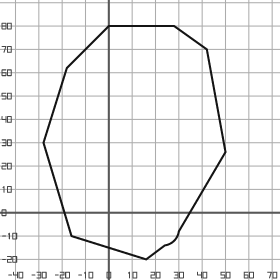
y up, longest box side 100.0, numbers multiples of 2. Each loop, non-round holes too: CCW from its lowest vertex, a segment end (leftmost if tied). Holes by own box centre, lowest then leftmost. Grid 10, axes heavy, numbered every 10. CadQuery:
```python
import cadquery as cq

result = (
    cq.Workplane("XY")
    .moveTo(16.0, -20.0)
    .lineTo(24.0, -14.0)
    .threePointArc((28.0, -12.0), (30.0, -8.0))
    .lineTo(50.0, 26.0)
    .lineTo(42.0, 70.0)
    .lineTo(28.0, 80.0)
    .lineTo(0.0, 80.0)
    .lineTo(-18.0, 62.0)
    .lineTo(-28.0, 30.0)
    .lineTo(-16.0, -10.0)
    .close()
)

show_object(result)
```